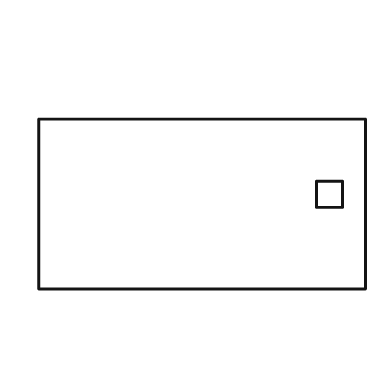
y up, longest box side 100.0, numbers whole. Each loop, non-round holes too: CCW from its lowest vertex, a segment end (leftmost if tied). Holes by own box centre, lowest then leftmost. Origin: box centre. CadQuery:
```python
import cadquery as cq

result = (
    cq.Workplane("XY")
    .moveTo(-50.0, -26.0)
    .lineTo(50.0, -26.0)
    .lineTo(50.0, 26.0)
    .lineTo(-50.0, 26.0)
    .close()
    .moveTo(35.0, -1.0)
    .lineTo(43.0, -1.0)
    .lineTo(43.0, 7.0)
    .lineTo(35.0, 7.0)
    .close()
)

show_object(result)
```